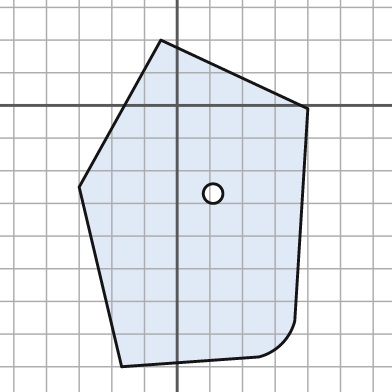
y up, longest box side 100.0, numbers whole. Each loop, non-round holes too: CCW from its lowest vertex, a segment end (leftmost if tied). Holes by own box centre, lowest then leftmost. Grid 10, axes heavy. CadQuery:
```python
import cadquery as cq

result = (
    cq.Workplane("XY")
    .moveTo(-17.0, -80.0)
    .lineTo(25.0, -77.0)
    .threePointArc((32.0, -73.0), (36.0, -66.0))
    .lineTo(40.0, -1.0)
    .lineTo(-5.0, 20.0)
    .lineTo(-30.0, -25.0)
    .close()
    .moveTo(11.0, -27.0)
    .circle(3.0)
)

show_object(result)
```